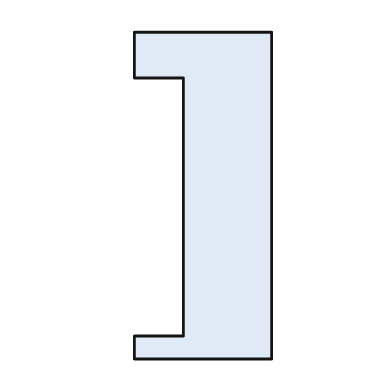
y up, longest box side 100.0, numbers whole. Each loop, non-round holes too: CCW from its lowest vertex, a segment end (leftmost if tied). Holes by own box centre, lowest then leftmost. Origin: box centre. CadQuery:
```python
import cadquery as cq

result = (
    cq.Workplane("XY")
    .moveTo(-21.0, -50.0)
    .lineTo(21.0, -50.0)
    .lineTo(21.0, 50.0)
    .lineTo(-21.0, 50.0)
    .lineTo(-21.0, 36.0)
    .lineTo(-6.0, 36.0)
    .lineTo(-6.0, -43.0)
    .lineTo(-21.0, -43.0)
    .close()
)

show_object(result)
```